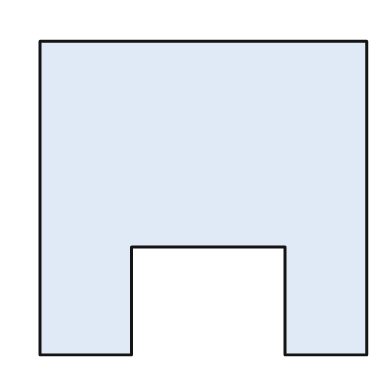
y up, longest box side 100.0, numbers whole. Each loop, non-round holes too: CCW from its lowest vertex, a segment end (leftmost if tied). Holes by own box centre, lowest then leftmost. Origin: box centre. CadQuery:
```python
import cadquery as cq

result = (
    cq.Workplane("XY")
    .moveTo(-50.0, -48.0)
    .lineTo(-22.0, -48.0)
    .lineTo(-22.0, -15.0)
    .lineTo(25.0, -15.0)
    .lineTo(25.0, -48.0)
    .lineTo(50.0, -48.0)
    .lineTo(50.0, 48.0)
    .lineTo(-50.0, 48.0)
    .close()
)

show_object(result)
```